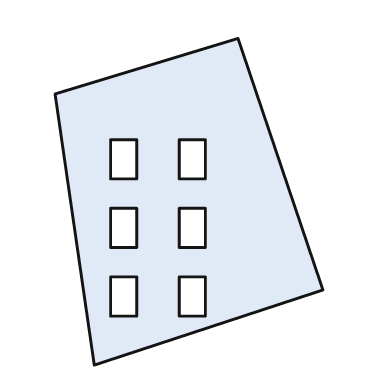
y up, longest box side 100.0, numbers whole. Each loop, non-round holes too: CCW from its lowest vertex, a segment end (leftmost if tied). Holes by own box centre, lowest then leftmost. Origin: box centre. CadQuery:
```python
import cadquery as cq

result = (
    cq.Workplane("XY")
    .moveTo(-29.0, -50.0)
    .lineTo(41.0, -27.0)
    .lineTo(15.0, 50.0)
    .lineTo(-41.0, 33.0)
    .close()
    .moveTo(-24.0, -35.0)
    .lineTo(-16.0, -35.0)
    .lineTo(-16.0, -23.0)
    .lineTo(-24.0, -23.0)
    .close()
    .moveTo(-3.0, -35.0)
    .lineTo(5.0, -35.0)
    .lineTo(5.0, -23.0)
    .lineTo(-3.0, -23.0)
    .close()
    .moveTo(-24.0, -14.0)
    .lineTo(-16.0, -14.0)
    .lineTo(-16.0, -2.0)
    .lineTo(-24.0, -2.0)
    .close()
    .moveTo(-3.0, -14.0)
    .lineTo(5.0, -14.0)
    .lineTo(5.0, -2.0)
    .lineTo(-3.0, -2.0)
    .close()
    .moveTo(-24.0, 7.0)
    .lineTo(-16.0, 7.0)
    .lineTo(-16.0, 19.0)
    .lineTo(-24.0, 19.0)
    .close()
    .moveTo(-3.0, 7.0)
    .lineTo(5.0, 7.0)
    .lineTo(5.0, 19.0)
    .lineTo(-3.0, 19.0)
    .close()
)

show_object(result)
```